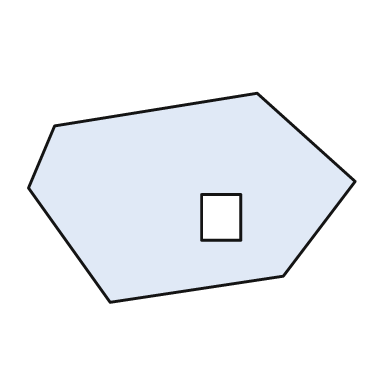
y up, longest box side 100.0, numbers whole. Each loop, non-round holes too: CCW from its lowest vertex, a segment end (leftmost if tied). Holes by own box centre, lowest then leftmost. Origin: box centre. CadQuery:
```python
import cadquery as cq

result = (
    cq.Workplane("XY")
    .moveTo(-25.0, -32.0)
    .lineTo(28.0, -24.0)
    .lineTo(50.0, 5.0)
    .lineTo(20.0, 32.0)
    .lineTo(-42.0, 22.0)
    .lineTo(-50.0, 3.0)
    .close()
    .moveTo(3.0, -13.0)
    .lineTo(15.0, -13.0)
    .lineTo(15.0, 1.0)
    .lineTo(3.0, 1.0)
    .close()
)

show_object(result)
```